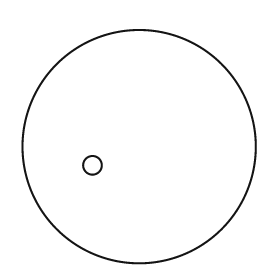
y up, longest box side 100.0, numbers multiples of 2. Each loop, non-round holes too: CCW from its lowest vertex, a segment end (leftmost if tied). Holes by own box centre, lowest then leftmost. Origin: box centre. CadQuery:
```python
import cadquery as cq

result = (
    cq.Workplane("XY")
    .moveTo(0.0, 0.0)
    .circle(50.0)
    .moveTo(-20.0, -8.0)
    .circle(4.0)
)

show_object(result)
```